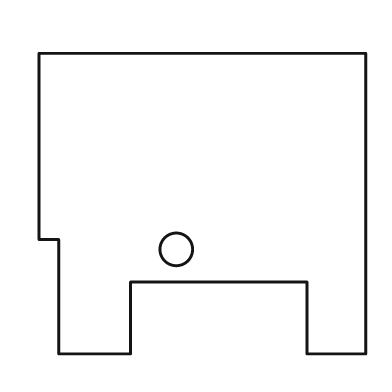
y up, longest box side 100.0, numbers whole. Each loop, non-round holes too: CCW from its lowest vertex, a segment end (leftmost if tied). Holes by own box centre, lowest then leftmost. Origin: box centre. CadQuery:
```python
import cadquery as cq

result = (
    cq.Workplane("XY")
    .moveTo(-44.0, -46.0)
    .lineTo(-22.0, -46.0)
    .lineTo(-22.0, -24.0)
    .lineTo(32.0, -24.0)
    .lineTo(32.0, -46.0)
    .lineTo(50.0, -46.0)
    .lineTo(50.0, 46.0)
    .lineTo(-50.0, 46.0)
    .lineTo(-50.0, -11.0)
    .lineTo(-44.0, -11.0)
    .close()
    .moveTo(-8.0, -14.0)
    .circle(5.0)
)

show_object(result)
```